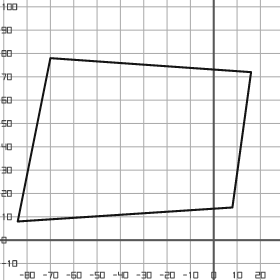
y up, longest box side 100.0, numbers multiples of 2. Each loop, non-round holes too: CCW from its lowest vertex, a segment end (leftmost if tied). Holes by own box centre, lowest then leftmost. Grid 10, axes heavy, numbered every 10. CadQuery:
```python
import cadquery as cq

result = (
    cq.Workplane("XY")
    .moveTo(-84.0, 8.0)
    .lineTo(8.0, 14.0)
    .lineTo(16.0, 72.0)
    .lineTo(-70.0, 78.0)
    .close()
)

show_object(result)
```